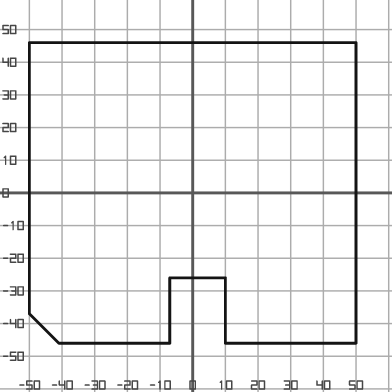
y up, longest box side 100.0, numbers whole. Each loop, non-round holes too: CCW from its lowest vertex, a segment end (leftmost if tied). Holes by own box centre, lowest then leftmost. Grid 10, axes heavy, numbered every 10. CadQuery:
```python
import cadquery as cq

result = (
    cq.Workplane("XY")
    .moveTo(-41.0, -46.0)
    .lineTo(-7.0, -46.0)
    .lineTo(-7.0, -26.0)
    .lineTo(10.0, -26.0)
    .lineTo(10.0, -46.0)
    .lineTo(50.0, -46.0)
    .lineTo(50.0, 46.0)
    .lineTo(-50.0, 46.0)
    .lineTo(-50.0, -37.0)
    .close()
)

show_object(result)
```